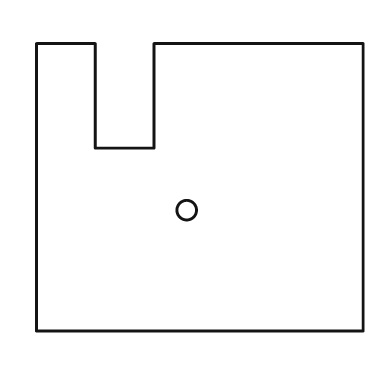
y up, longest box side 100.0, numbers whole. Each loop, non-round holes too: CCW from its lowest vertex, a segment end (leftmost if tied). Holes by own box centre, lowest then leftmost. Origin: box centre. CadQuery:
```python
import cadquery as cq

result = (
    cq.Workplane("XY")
    .moveTo(-50.0, -44.0)
    .lineTo(50.0, -44.0)
    .lineTo(50.0, 44.0)
    .lineTo(-14.0, 44.0)
    .lineTo(-14.0, 12.0)
    .lineTo(-32.0, 12.0)
    .lineTo(-32.0, 44.0)
    .lineTo(-50.0, 44.0)
    .close()
    .moveTo(-4.0, -7.0)
    .circle(3.0)
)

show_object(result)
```